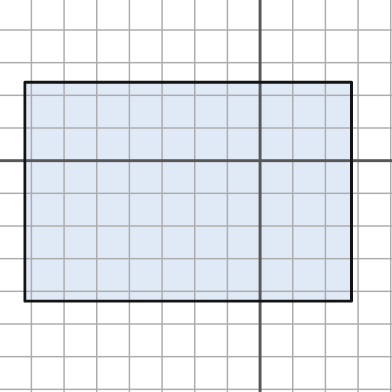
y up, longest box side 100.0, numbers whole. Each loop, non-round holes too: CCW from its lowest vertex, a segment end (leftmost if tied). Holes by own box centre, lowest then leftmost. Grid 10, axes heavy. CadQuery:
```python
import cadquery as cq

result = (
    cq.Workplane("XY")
    .moveTo(-72.0, -43.0)
    .lineTo(28.0, -43.0)
    .lineTo(28.0, 24.0)
    .lineTo(-72.0, 24.0)
    .close()
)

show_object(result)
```